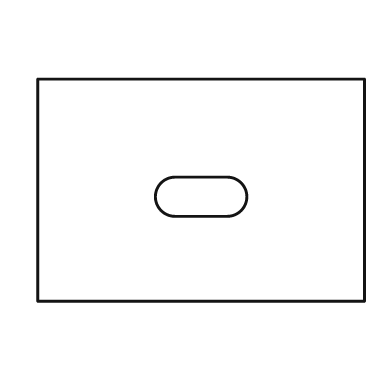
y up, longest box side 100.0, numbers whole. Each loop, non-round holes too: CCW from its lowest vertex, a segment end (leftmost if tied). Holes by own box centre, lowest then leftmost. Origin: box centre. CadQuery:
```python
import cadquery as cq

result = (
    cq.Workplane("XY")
    .moveTo(-50.0, -34.0)
    .lineTo(50.0, -34.0)
    .lineTo(50.0, 34.0)
    .lineTo(-50.0, 34.0)
    .close()
    .moveTo(-8.0, -8.0)
    .lineTo(8.0, -8.0)
    .threePointArc((14.0, -2.0), (8.0, 4.0))
    .lineTo(-8.0, 4.0)
    .threePointArc((-14.0, -2.0), (-8.0, -8.0))
    .close()
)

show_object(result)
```